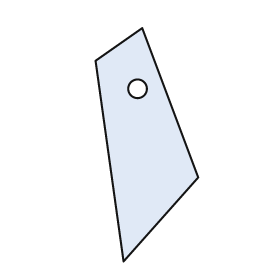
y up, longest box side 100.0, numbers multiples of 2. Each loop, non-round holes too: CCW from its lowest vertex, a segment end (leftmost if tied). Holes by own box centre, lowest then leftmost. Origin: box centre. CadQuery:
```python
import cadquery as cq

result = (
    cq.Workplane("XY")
    .moveTo(-10.0, -50.0)
    .lineTo(22.0, -14.0)
    .lineTo(-2.0, 50.0)
    .lineTo(-22.0, 36.0)
    .close()
    .moveTo(-4.0, 24.0)
    .circle(4.0)
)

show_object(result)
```